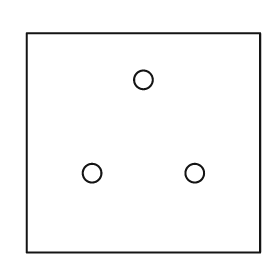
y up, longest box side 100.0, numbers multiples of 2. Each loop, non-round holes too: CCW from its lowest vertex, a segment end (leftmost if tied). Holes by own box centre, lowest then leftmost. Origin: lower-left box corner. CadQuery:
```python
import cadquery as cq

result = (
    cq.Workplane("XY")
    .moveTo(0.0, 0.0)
    .lineTo(100.0, 0.0)
    .lineTo(100.0, 94.0)
    .lineTo(0.0, 94.0)
    .close()
    .moveTo(28.0, 34.0)
    .circle(4.0)
    .moveTo(72.0, 34.0)
    .circle(4.0)
    .moveTo(50.0, 74.0)
    .circle(4.0)
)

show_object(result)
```